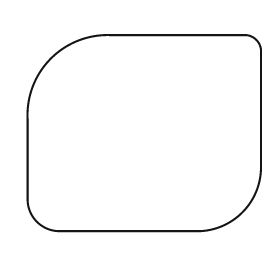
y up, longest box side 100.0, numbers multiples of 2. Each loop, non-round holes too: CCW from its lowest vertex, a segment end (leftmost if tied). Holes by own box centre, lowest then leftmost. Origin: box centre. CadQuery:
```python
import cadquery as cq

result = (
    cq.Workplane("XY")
    .moveTo(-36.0, -42.0)
    .lineTo(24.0, -42.0)
    .threePointArc((42.0, -34.0), (50.0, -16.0))
    .lineTo(50.0, 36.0)
    .threePointArc((48.0, 40.0), (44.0, 42.0))
    .lineTo(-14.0, 42.0)
    .threePointArc((-40.0, 32.0), (-50.0, 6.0))
    .lineTo(-50.0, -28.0)
    .threePointArc((-46.0, -38.0), (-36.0, -42.0))
    .close()
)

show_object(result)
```